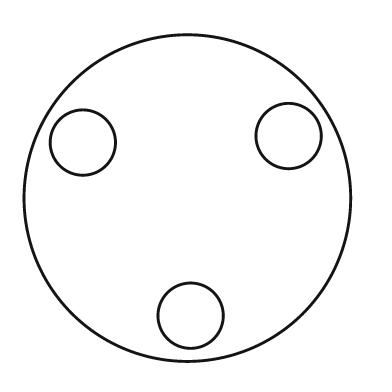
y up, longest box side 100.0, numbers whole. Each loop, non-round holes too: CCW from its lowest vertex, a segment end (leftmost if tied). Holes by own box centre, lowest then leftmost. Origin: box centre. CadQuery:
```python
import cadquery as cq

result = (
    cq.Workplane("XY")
    .moveTo(0.0, 0.0)
    .circle(50.0)
    .moveTo(1.0, -36.0)
    .circle(10.0)
    .moveTo(-32.0, 17.0)
    .circle(10.0)
    .moveTo(31.0, 19.0)
    .circle(10.0)
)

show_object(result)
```